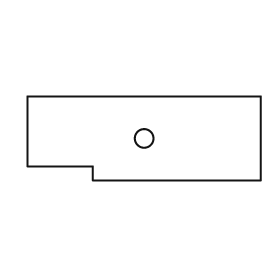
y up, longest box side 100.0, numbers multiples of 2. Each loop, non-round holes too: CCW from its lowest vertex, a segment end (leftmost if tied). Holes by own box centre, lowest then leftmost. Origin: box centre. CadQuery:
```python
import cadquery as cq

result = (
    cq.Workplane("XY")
    .moveTo(-22.0, -18.0)
    .lineTo(50.0, -18.0)
    .lineTo(50.0, 18.0)
    .lineTo(-50.0, 18.0)
    .lineTo(-50.0, -12.0)
    .lineTo(-22.0, -12.0)
    .close()
    .moveTo(0.0, 0.0)
    .circle(4.0)
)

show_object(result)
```